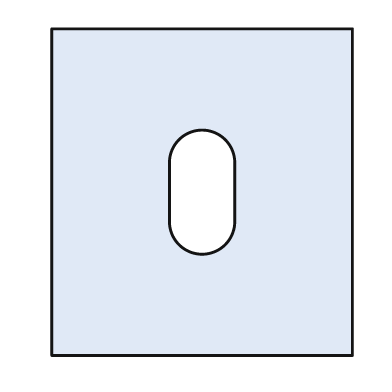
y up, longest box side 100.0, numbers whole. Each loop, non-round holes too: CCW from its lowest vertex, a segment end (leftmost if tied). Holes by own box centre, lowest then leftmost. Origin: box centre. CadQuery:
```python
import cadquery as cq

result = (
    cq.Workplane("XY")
    .moveTo(-46.0, -50.0)
    .lineTo(46.0, -50.0)
    .lineTo(46.0, 50.0)
    .lineTo(-46.0, 50.0)
    .close()
    .moveTo(-10.0, -9.0)
    .threePointArc((0.0, -19.0), (10.0, -9.0))
    .lineTo(10.0, 9.0)
    .threePointArc((0.0, 19.0), (-10.0, 9.0))
    .close()
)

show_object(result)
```